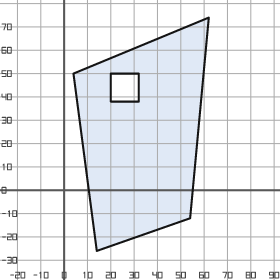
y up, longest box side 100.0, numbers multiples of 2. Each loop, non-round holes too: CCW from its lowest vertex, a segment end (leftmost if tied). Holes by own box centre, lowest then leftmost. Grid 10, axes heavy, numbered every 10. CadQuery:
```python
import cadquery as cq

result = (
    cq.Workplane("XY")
    .moveTo(14.0, -26.0)
    .lineTo(54.0, -12.0)
    .lineTo(62.0, 74.0)
    .lineTo(4.0, 50.0)
    .close()
    .moveTo(20.0, 38.0)
    .lineTo(32.0, 38.0)
    .lineTo(32.0, 50.0)
    .lineTo(20.0, 50.0)
    .close()
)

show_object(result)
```